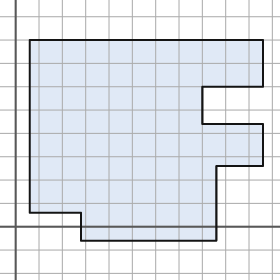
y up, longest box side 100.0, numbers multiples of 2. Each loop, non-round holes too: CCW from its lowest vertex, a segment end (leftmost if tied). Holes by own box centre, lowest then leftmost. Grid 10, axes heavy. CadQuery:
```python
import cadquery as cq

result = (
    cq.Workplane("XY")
    .moveTo(28.0, -6.0)
    .lineTo(86.0, -6.0)
    .lineTo(86.0, 26.0)
    .lineTo(106.0, 26.0)
    .lineTo(106.0, 44.0)
    .lineTo(80.0, 44.0)
    .lineTo(80.0, 60.0)
    .lineTo(106.0, 60.0)
    .lineTo(106.0, 80.0)
    .lineTo(6.0, 80.0)
    .lineTo(6.0, 6.0)
    .lineTo(28.0, 6.0)
    .close()
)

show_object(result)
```